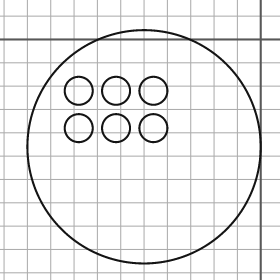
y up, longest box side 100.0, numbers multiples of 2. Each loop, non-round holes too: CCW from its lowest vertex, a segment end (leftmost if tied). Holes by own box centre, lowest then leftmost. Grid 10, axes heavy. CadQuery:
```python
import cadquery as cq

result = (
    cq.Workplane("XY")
    .moveTo(-50.0, -46.0)
    .circle(50.0)
    .moveTo(-78.0, -38.0)
    .circle(6.0)
    .moveTo(-62.0, -38.0)
    .circle(6.0)
    .moveTo(-46.0, -38.0)
    .circle(6.0)
    .moveTo(-78.0, -22.0)
    .circle(6.0)
    .moveTo(-62.0, -22.0)
    .circle(6.0)
    .moveTo(-46.0, -22.0)
    .circle(6.0)
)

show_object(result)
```